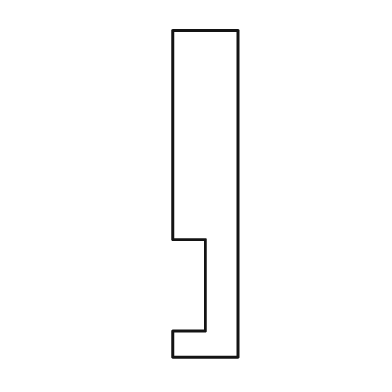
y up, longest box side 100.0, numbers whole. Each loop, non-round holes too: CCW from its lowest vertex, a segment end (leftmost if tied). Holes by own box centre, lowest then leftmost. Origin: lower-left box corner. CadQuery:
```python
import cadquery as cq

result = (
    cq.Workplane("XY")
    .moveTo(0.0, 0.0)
    .lineTo(20.0, 0.0)
    .lineTo(20.0, 100.0)
    .lineTo(0.0, 100.0)
    .lineTo(0.0, 36.0)
    .lineTo(10.0, 36.0)
    .lineTo(10.0, 8.0)
    .lineTo(0.0, 8.0)
    .close()
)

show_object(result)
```